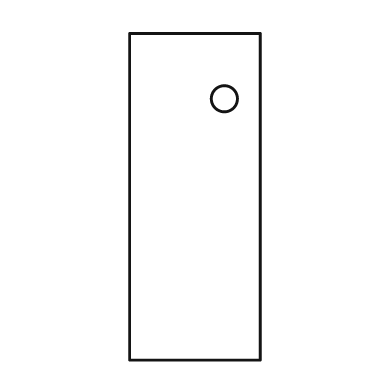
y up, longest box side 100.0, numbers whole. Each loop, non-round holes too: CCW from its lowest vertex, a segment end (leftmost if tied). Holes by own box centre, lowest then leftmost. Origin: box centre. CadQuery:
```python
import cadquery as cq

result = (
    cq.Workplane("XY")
    .moveTo(-20.0, -50.0)
    .lineTo(20.0, -50.0)
    .lineTo(20.0, 50.0)
    .lineTo(-20.0, 50.0)
    .close()
    .moveTo(9.0, 30.0)
    .circle(4.0)
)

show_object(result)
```